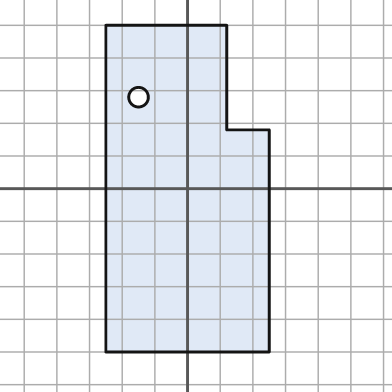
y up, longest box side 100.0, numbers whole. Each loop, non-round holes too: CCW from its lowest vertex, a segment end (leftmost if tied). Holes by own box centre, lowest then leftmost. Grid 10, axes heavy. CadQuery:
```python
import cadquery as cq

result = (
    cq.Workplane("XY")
    .moveTo(-25.0, -50.0)
    .lineTo(25.0, -50.0)
    .lineTo(25.0, 18.0)
    .lineTo(12.0, 18.0)
    .lineTo(12.0, 50.0)
    .lineTo(-25.0, 50.0)
    .close()
    .moveTo(-15.0, 28.0)
    .circle(3.0)
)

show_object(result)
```